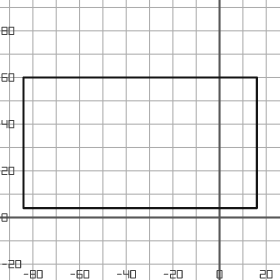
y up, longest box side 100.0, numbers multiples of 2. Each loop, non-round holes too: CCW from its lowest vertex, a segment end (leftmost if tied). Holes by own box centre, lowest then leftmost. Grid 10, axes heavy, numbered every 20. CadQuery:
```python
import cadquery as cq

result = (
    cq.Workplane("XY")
    .moveTo(-84.0, 4.0)
    .lineTo(16.0, 4.0)
    .lineTo(16.0, 60.0)
    .lineTo(-84.0, 60.0)
    .close()
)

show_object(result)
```